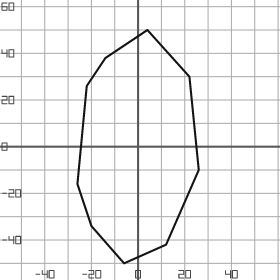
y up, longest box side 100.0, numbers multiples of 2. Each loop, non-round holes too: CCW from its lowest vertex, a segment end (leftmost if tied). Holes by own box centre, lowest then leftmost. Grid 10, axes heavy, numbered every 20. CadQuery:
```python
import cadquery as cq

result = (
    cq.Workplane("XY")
    .moveTo(-6.0, -50.0)
    .lineTo(12.0, -42.0)
    .lineTo(26.0, -10.0)
    .lineTo(22.0, 30.0)
    .lineTo(4.0, 50.0)
    .lineTo(-14.0, 38.0)
    .lineTo(-22.0, 26.0)
    .lineTo(-26.0, -16.0)
    .lineTo(-20.0, -34.0)
    .close()
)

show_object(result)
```